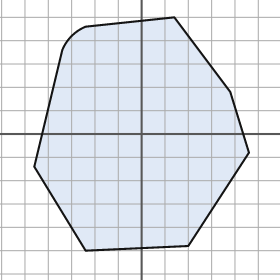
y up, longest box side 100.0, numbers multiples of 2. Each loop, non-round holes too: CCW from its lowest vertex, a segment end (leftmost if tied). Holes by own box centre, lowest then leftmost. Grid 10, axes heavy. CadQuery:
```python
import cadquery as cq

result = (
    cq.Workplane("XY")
    .moveTo(-24.0, -50.0)
    .lineTo(20.0, -48.0)
    .lineTo(46.0, -8.0)
    .lineTo(38.0, 18.0)
    .lineTo(14.0, 50.0)
    .lineTo(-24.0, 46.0)
    .threePointArc((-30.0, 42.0), (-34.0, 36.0))
    .lineTo(-46.0, -14.0)
    .close()
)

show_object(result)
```